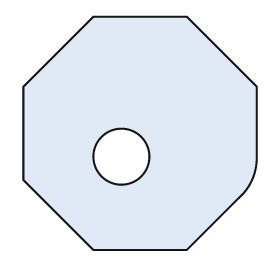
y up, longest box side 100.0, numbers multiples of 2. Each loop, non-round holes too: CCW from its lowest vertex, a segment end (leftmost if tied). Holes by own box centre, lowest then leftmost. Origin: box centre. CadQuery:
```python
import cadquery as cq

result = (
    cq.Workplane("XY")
    .moveTo(-20.0, -50.0)
    .lineTo(20.0, -50.0)
    .lineTo(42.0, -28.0)
    .threePointArc((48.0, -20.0), (50.0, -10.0))
    .lineTo(50.0, 20.0)
    .lineTo(20.0, 50.0)
    .lineTo(-20.0, 50.0)
    .lineTo(-50.0, 20.0)
    .lineTo(-50.0, -20.0)
    .close()
    .moveTo(-8.0, -10.0)
    .circle(12.0)
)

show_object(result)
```